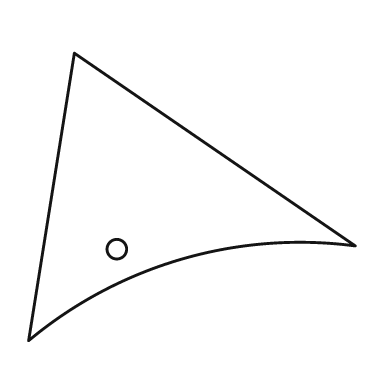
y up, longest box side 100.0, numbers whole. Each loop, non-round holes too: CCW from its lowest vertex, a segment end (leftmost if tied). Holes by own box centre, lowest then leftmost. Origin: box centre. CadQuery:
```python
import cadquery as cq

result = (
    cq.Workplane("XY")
    .moveTo(-50.0, -44.0)
    .threePointArc((-3.0, -19.0), (50.0, -15.0))
    .lineTo(-36.0, 44.0)
    .close()
    .moveTo(-23.0, -16.0)
    .circle(3.0)
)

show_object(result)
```